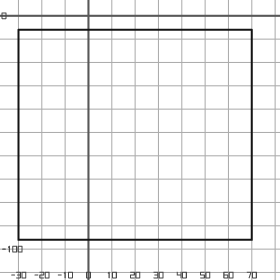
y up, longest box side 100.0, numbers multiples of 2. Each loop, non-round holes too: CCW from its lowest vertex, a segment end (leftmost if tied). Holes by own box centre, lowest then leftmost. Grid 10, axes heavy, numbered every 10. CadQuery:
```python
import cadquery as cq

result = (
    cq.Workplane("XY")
    .moveTo(-30.0, -96.0)
    .lineTo(70.0, -96.0)
    .lineTo(70.0, -6.0)
    .lineTo(-30.0, -6.0)
    .close()
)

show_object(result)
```